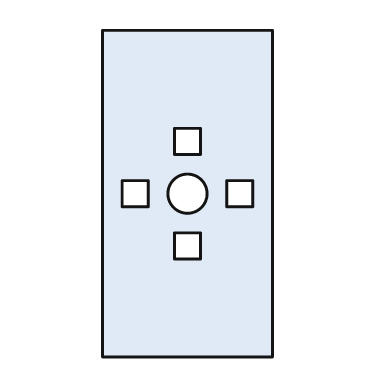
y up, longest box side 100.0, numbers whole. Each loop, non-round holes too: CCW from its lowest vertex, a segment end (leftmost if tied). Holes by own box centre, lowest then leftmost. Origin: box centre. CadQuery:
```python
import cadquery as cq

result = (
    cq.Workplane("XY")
    .moveTo(-26.0, -50.0)
    .lineTo(26.0, -50.0)
    .lineTo(26.0, 50.0)
    .lineTo(-26.0, 50.0)
    .close()
    .moveTo(-4.0, -20.0)
    .lineTo(4.0, -20.0)
    .lineTo(4.0, -12.0)
    .lineTo(-4.0, -12.0)
    .close()
    .moveTo(-20.0, -4.0)
    .lineTo(-12.0, -4.0)
    .lineTo(-12.0, 4.0)
    .lineTo(-20.0, 4.0)
    .close()
    .moveTo(0.0, 0.0)
    .circle(6.0)
    .moveTo(12.0, -4.0)
    .lineTo(20.0, -4.0)
    .lineTo(20.0, 4.0)
    .lineTo(12.0, 4.0)
    .close()
    .moveTo(-4.0, 12.0)
    .lineTo(4.0, 12.0)
    .lineTo(4.0, 20.0)
    .lineTo(-4.0, 20.0)
    .close()
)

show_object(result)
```